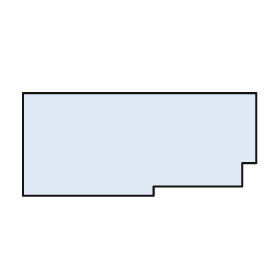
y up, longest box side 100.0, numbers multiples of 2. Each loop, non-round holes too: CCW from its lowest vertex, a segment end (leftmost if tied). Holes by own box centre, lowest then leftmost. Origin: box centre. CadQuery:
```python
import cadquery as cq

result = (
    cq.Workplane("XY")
    .moveTo(-50.0, -22.0)
    .lineTo(6.0, -22.0)
    .lineTo(6.0, -18.0)
    .lineTo(44.0, -18.0)
    .lineTo(44.0, -8.0)
    .lineTo(50.0, -8.0)
    .lineTo(50.0, 22.0)
    .lineTo(-50.0, 22.0)
    .close()
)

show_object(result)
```